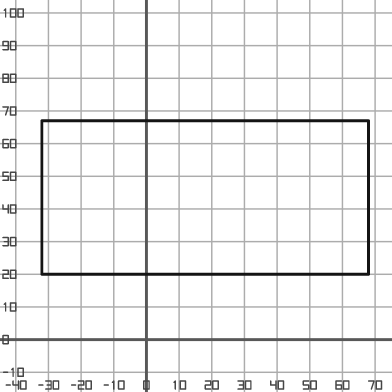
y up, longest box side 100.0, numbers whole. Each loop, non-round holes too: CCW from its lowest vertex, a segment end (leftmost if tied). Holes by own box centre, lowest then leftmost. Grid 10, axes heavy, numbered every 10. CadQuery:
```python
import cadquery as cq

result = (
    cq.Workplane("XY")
    .moveTo(-32.0, 20.0)
    .lineTo(68.0, 20.0)
    .lineTo(68.0, 67.0)
    .lineTo(-32.0, 67.0)
    .close()
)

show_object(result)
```